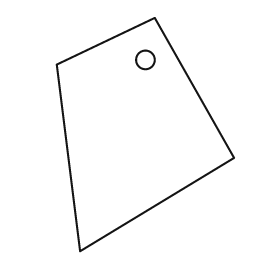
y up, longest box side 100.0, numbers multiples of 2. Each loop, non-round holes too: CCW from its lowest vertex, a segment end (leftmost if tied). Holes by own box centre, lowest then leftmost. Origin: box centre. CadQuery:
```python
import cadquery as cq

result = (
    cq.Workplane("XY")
    .moveTo(-28.0, -50.0)
    .lineTo(38.0, -10.0)
    .lineTo(4.0, 50.0)
    .lineTo(-38.0, 30.0)
    .close()
    .moveTo(0.0, 32.0)
    .circle(4.0)
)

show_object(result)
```